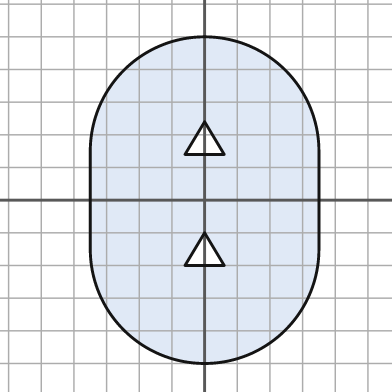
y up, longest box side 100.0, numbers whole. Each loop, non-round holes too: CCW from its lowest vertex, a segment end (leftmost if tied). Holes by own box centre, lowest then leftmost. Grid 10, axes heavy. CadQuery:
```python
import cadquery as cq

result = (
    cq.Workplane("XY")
    .moveTo(-35.0, -15.0)
    .threePointArc((0.0, -50.0), (35.0, -15.0))
    .lineTo(35.0, 15.0)
    .threePointArc((0.0, 50.0), (-35.0, 15.0))
    .close()
    .moveTo(-6.0, -20.0)
    .lineTo(6.0, -20.0)
    .lineTo(0.0, -10.0)
    .close()
    .moveTo(-6.0, 14.0)
    .lineTo(6.0, 14.0)
    .lineTo(0.0, 24.0)
    .close()
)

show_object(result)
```